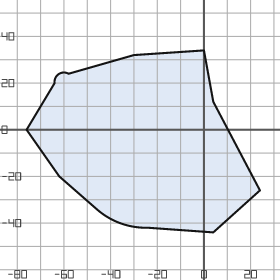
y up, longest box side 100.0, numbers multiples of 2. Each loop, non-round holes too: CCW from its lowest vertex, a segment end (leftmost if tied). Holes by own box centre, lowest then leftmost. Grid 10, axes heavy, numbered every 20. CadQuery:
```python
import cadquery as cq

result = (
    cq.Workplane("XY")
    .moveTo(4.0, -44.0)
    .lineTo(24.0, -26.0)
    .lineTo(4.0, 12.0)
    .lineTo(0.0, 34.0)
    .lineTo(-30.0, 32.0)
    .lineTo(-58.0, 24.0)
    .threePointArc((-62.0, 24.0), (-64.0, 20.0))
    .lineTo(-76.0, 0.0)
    .lineTo(-62.0, -20.0)
    .lineTo(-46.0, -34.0)
    .threePointArc((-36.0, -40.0), (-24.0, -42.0))
    .close()
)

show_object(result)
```